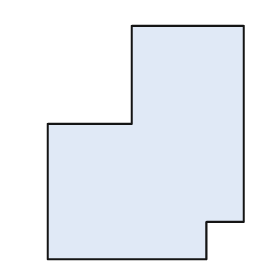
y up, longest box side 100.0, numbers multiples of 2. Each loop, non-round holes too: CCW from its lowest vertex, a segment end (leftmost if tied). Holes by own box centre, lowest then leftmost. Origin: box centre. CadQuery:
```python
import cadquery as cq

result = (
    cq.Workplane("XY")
    .moveTo(-42.0, -50.0)
    .lineTo(26.0, -50.0)
    .lineTo(26.0, -34.0)
    .lineTo(42.0, -34.0)
    .lineTo(42.0, 50.0)
    .lineTo(-6.0, 50.0)
    .lineTo(-6.0, 8.0)
    .lineTo(-42.0, 8.0)
    .close()
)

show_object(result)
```